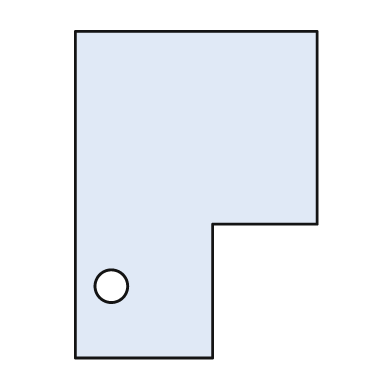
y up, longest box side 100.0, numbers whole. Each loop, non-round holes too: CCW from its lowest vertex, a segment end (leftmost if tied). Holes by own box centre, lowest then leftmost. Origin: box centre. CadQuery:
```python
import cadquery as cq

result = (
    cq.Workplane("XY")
    .moveTo(-37.0, -50.0)
    .lineTo(5.0, -50.0)
    .lineTo(5.0, -9.0)
    .lineTo(37.0, -9.0)
    .lineTo(37.0, 50.0)
    .lineTo(-37.0, 50.0)
    .close()
    .moveTo(-26.0, -28.0)
    .circle(5.0)
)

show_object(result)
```